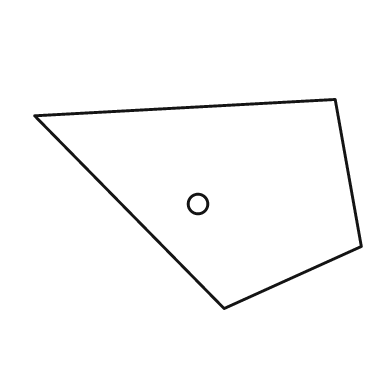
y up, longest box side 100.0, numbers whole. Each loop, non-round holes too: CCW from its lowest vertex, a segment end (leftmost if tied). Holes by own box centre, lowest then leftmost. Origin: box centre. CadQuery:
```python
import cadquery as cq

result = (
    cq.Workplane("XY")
    .moveTo(8.0, -32.0)
    .lineTo(50.0, -13.0)
    .lineTo(42.0, 32.0)
    .lineTo(-50.0, 27.0)
    .close()
    .moveTo(0.0, 0.0)
    .circle(3.0)
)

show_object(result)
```